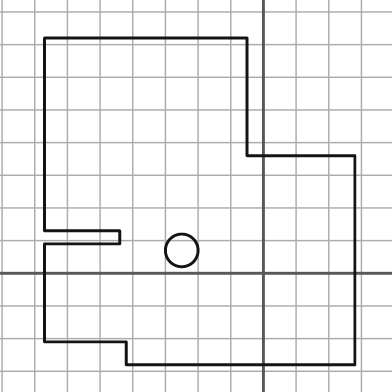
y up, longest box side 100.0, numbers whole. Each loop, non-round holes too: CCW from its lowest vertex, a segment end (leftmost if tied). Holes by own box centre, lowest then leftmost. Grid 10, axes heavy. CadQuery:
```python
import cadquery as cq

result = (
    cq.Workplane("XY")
    .moveTo(-42.0, -28.0)
    .lineTo(28.0, -28.0)
    .lineTo(28.0, 36.0)
    .lineTo(-5.0, 36.0)
    .lineTo(-5.0, 72.0)
    .lineTo(-67.0, 72.0)
    .lineTo(-67.0, 13.0)
    .lineTo(-44.0, 13.0)
    .lineTo(-44.0, 9.0)
    .lineTo(-67.0, 9.0)
    .lineTo(-67.0, -21.0)
    .lineTo(-42.0, -21.0)
    .close()
    .moveTo(-25.0, 7.0)
    .circle(5.0)
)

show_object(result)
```